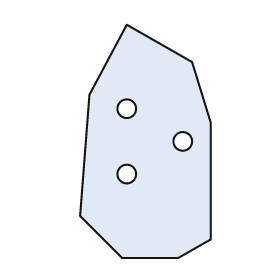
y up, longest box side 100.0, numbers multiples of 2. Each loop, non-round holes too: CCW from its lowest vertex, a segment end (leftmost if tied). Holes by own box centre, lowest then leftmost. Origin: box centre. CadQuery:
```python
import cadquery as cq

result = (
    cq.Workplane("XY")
    .moveTo(-10.0, -50.0)
    .lineTo(14.0, -50.0)
    .lineTo(28.0, -42.0)
    .lineTo(28.0, 8.0)
    .lineTo(20.0, 34.0)
    .lineTo(-8.0, 50.0)
    .lineTo(-24.0, 20.0)
    .lineTo(-28.0, -32.0)
    .close()
    .moveTo(-8.0, -14.0)
    .circle(4.0)
    .moveTo(16.0, 0.0)
    .circle(4.0)
    .moveTo(-8.0, 14.0)
    .circle(4.0)
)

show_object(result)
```